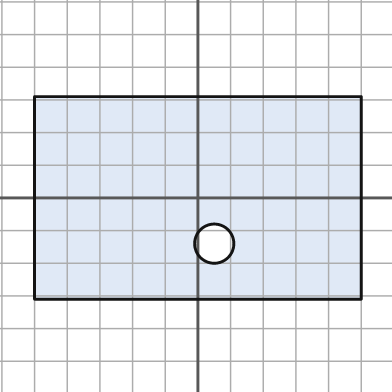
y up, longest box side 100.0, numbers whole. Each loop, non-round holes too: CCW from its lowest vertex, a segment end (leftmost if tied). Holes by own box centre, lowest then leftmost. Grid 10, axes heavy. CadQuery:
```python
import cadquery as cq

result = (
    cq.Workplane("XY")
    .moveTo(-50.0, -31.0)
    .lineTo(50.0, -31.0)
    .lineTo(50.0, 31.0)
    .lineTo(-50.0, 31.0)
    .close()
    .moveTo(5.0, -14.0)
    .circle(6.0)
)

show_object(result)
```